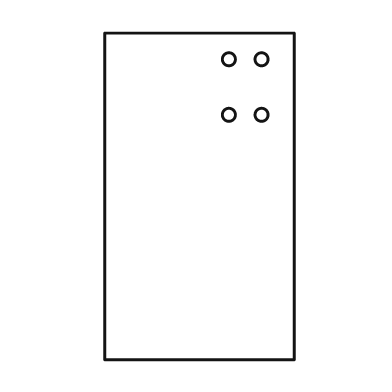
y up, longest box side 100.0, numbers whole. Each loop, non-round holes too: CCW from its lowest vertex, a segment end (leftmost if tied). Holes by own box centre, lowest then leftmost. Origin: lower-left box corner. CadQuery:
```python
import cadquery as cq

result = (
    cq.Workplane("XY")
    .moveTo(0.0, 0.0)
    .lineTo(58.0, 0.0)
    .lineTo(58.0, 100.0)
    .lineTo(0.0, 100.0)
    .close()
    .moveTo(38.0, 75.0)
    .circle(2.0)
    .moveTo(48.0, 75.0)
    .circle(2.0)
    .moveTo(38.0, 92.0)
    .circle(2.0)
    .moveTo(48.0, 92.0)
    .circle(2.0)
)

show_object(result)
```